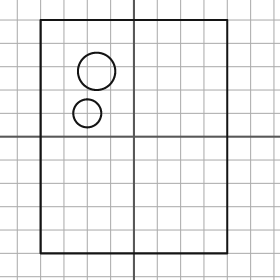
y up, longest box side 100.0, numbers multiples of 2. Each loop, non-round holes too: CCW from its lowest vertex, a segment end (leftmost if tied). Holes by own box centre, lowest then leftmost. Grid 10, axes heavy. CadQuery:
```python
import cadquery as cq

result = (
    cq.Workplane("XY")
    .moveTo(-40.0, -50.0)
    .lineTo(40.0, -50.0)
    .lineTo(40.0, 50.0)
    .lineTo(-40.0, 50.0)
    .close()
    .moveTo(-20.0, 10.0)
    .circle(6.0)
    .moveTo(-16.0, 28.0)
    .circle(8.0)
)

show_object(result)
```